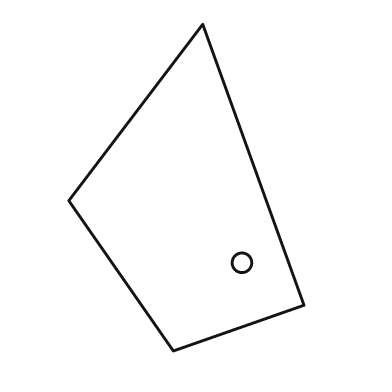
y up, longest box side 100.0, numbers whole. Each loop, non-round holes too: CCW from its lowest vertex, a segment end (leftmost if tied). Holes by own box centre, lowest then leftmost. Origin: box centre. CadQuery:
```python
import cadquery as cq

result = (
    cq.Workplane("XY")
    .moveTo(-4.0, -50.0)
    .lineTo(36.0, -36.0)
    .lineTo(5.0, 50.0)
    .lineTo(-36.0, -4.0)
    .close()
    .moveTo(17.0, -23.0)
    .circle(3.0)
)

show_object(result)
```